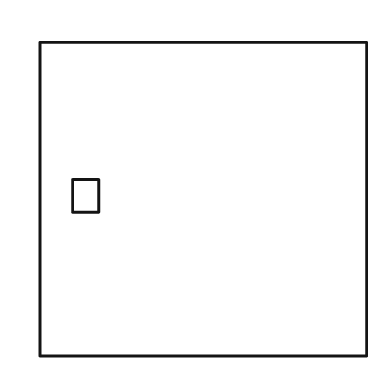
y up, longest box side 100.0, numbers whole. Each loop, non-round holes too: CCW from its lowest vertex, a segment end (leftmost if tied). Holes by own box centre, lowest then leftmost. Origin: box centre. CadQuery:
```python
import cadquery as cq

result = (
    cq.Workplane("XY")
    .moveTo(-50.0, -48.0)
    .lineTo(50.0, -48.0)
    .lineTo(50.0, 48.0)
    .lineTo(-50.0, 48.0)
    .close()
    .moveTo(-40.0, -4.0)
    .lineTo(-32.0, -4.0)
    .lineTo(-32.0, 6.0)
    .lineTo(-40.0, 6.0)
    .close()
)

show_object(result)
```